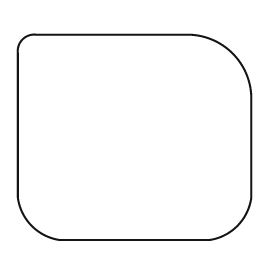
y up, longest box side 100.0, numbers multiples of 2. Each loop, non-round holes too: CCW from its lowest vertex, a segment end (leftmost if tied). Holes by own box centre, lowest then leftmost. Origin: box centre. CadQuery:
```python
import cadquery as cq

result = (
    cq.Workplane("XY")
    .moveTo(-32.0, -44.0)
    .lineTo(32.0, -44.0)
    .threePointArc((44.0, -38.0), (50.0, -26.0))
    .lineTo(50.0, 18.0)
    .threePointArc((42.0, 36.0), (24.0, 44.0))
    .lineTo(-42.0, 44.0)
    .threePointArc((-48.0, 42.0), (-50.0, 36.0))
    .lineTo(-50.0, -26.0)
    .threePointArc((-44.0, -38.0), (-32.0, -44.0))
    .close()
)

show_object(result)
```